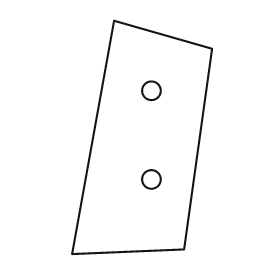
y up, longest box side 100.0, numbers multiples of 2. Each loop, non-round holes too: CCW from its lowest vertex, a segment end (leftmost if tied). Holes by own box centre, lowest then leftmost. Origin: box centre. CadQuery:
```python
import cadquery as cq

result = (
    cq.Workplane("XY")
    .moveTo(-30.0, -50.0)
    .lineTo(18.0, -48.0)
    .lineTo(30.0, 38.0)
    .lineTo(-12.0, 50.0)
    .close()
    .moveTo(4.0, -18.0)
    .circle(4.0)
    .moveTo(4.0, 20.0)
    .circle(4.0)
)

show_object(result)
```